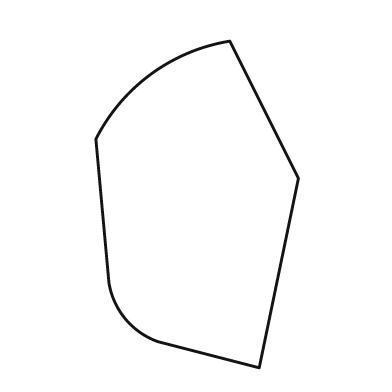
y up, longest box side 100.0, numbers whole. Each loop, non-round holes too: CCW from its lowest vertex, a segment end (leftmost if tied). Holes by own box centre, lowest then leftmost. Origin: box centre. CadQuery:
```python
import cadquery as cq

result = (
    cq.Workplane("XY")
    .moveTo(19.0, -50.0)
    .lineTo(31.0, 8.0)
    .lineTo(10.0, 50.0)
    .threePointArc((-14.0, 40.0), (-31.0, 20.0))
    .lineTo(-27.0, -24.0)
    .threePointArc((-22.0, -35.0), (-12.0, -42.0))
    .close()
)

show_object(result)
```